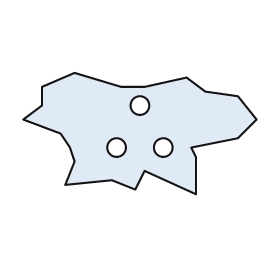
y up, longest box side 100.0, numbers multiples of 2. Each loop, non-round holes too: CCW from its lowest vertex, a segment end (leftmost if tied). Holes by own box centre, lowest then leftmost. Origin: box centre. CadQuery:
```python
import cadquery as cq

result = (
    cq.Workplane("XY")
    .moveTo(24.0, -26.0)
    .lineTo(24.0, -10.0)
    .lineTo(22.0, -6.0)
    .lineTo(42.0, -2.0)
    .lineTo(50.0, 6.0)
    .lineTo(42.0, 16.0)
    .lineTo(28.0, 18.0)
    .lineTo(20.0, 24.0)
    .lineTo(2.0, 20.0)
    .lineTo(-8.0, 20.0)
    .lineTo(-28.0, 26.0)
    .lineTo(-42.0, 20.0)
    .lineTo(-42.0, 12.0)
    .lineTo(-50.0, 6.0)
    .lineTo(-34.0, 0.0)
    .lineTo(-30.0, -6.0)
    .lineTo(-28.0, -12.0)
    .lineTo(-32.0, -22.0)
    .lineTo(-12.0, -20.0)
    .lineTo(-2.0, -24.0)
    .lineTo(2.0, -16.0)
    .close()
    .moveTo(-10.0, -6.0)
    .circle(4.0)
    .moveTo(10.0, -6.0)
    .circle(4.0)
    .moveTo(0.0, 12.0)
    .circle(4.0)
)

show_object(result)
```